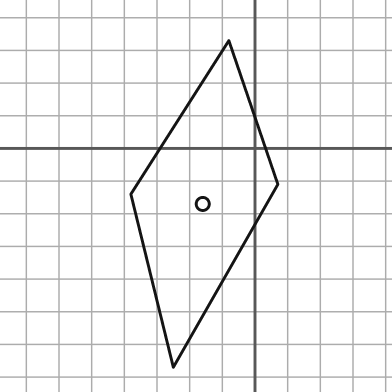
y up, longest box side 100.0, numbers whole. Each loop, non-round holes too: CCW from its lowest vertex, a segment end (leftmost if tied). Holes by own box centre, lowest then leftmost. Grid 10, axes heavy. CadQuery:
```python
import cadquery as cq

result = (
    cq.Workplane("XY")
    .moveTo(-25.0, -67.0)
    .lineTo(7.0, -11.0)
    .lineTo(-8.0, 33.0)
    .lineTo(-38.0, -14.0)
    .close()
    .moveTo(-16.0, -17.0)
    .circle(2.0)
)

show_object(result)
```